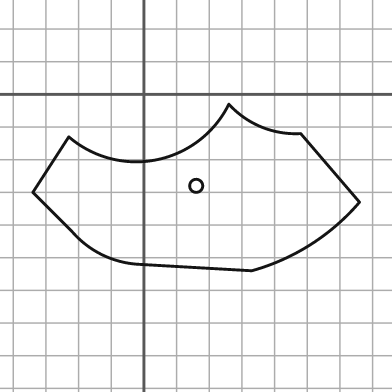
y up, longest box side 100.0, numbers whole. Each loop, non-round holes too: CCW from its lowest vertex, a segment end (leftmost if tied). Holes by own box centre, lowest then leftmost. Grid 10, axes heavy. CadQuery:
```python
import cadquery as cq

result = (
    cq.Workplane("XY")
    .moveTo(33.0, -54.0)
    .threePointArc((51.0, -46.0), (66.0, -33.0))
    .lineTo(48.0, -12.0)
    .threePointArc((36.0, -10.0), (26.0, -3.0))
    .threePointArc((4.0, -20.0), (-23.0, -13.0))
    .lineTo(-34.0, -30.0)
    .lineTo(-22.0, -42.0)
    .threePointArc((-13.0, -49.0), (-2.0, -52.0))
    .close()
    .moveTo(16.0, -28.0)
    .circle(2.0)
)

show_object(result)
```